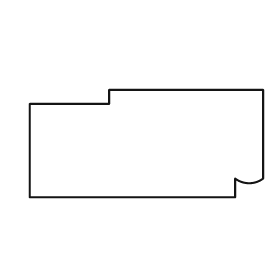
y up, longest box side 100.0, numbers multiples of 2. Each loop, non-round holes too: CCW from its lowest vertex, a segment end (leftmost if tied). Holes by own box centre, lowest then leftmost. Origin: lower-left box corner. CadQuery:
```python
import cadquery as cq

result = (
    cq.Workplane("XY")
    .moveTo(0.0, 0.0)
    .lineTo(88.0, 0.0)
    .lineTo(88.0, 8.0)
    .threePointArc((94.0, 6.0), (100.0, 8.0))
    .lineTo(100.0, 46.0)
    .lineTo(34.0, 46.0)
    .lineTo(34.0, 40.0)
    .lineTo(0.0, 40.0)
    .close()
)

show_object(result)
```